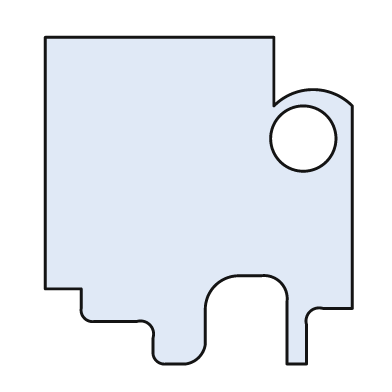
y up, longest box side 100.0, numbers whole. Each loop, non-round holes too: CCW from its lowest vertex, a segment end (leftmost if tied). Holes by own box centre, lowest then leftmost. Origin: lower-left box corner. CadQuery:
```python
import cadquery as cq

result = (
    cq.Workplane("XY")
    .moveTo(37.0, 0.0)
    .lineTo(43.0, 0.0)
    .threePointArc((47.0, 2.0), (49.0, 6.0))
    .lineTo(49.0, 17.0)
    .threePointArc((52.0, 24.0), (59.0, 27.0))
    .lineTo(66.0, 27.0)
    .threePointArc((72.0, 25.0), (74.0, 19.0))
    .lineTo(74.0, 0.0)
    .lineTo(80.0, 0.0)
    .lineTo(80.0, 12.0)
    .threePointArc((81.0, 16.0), (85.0, 17.0))
    .lineTo(94.0, 17.0)
    .lineTo(94.0, 79.0)
    .threePointArc((82.0, 84.0), (70.0, 79.0))
    .lineTo(70.0, 100.0)
    .lineTo(0.0, 100.0)
    .lineTo(0.0, 23.0)
    .lineTo(11.0, 23.0)
    .lineTo(11.0, 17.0)
    .threePointArc((12.0, 14.0), (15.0, 13.0))
    .lineTo(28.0, 13.0)
    .threePointArc((32.0, 12.0), (33.0, 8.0))
    .lineTo(33.0, 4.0)
    .threePointArc((34.0, 1.0), (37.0, 0.0))
    .close()
    .moveTo(79.0, 69.0)
    .circle(10.0)
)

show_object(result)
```